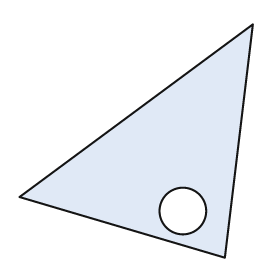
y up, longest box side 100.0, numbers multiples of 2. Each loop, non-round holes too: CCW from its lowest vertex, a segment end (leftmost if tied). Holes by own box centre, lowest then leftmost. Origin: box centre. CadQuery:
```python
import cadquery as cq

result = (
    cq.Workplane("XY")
    .moveTo(38.0, -50.0)
    .lineTo(50.0, 50.0)
    .lineTo(-50.0, -24.0)
    .close()
    .moveTo(20.0, -30.0)
    .circle(10.0)
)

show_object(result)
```